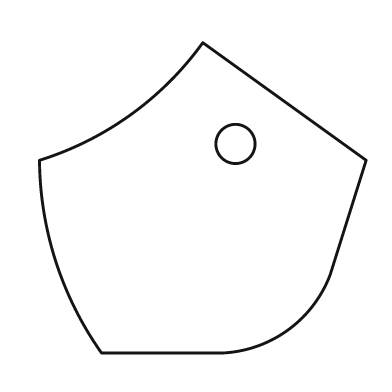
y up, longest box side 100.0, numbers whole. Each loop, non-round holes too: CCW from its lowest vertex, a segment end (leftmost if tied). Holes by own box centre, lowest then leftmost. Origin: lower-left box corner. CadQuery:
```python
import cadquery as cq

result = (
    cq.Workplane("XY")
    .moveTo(19.0, 0.0)
    .lineTo(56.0, 0.0)
    .threePointArc((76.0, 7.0), (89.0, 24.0))
    .lineTo(100.0, 59.0)
    .lineTo(50.0, 95.0)
    .threePointArc((28.0, 73.0), (0.0, 59.0))
    .threePointArc((5.0, 28.0), (19.0, 0.0))
    .close()
    .moveTo(60.0, 64.0)
    .circle(6.0)
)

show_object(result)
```